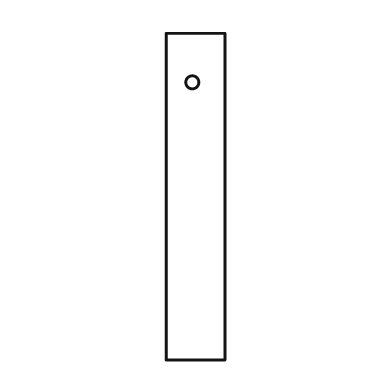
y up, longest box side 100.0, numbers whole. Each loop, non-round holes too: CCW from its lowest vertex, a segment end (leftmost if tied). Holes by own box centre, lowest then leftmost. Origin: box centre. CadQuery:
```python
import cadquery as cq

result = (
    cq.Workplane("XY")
    .moveTo(-9.0, -50.0)
    .lineTo(9.0, -50.0)
    .lineTo(9.0, 50.0)
    .lineTo(-9.0, 50.0)
    .close()
    .moveTo(-1.0, 35.0)
    .circle(2.0)
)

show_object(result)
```